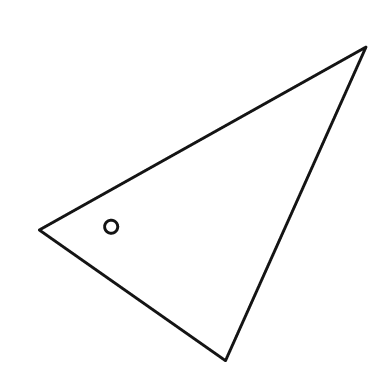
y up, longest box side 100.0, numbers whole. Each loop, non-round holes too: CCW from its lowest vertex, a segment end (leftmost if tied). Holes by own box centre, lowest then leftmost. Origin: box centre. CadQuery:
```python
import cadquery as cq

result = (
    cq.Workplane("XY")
    .moveTo(7.0, -48.0)
    .lineTo(50.0, 48.0)
    .lineTo(-50.0, -8.0)
    .close()
    .moveTo(-28.0, -7.0)
    .circle(2.0)
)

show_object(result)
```